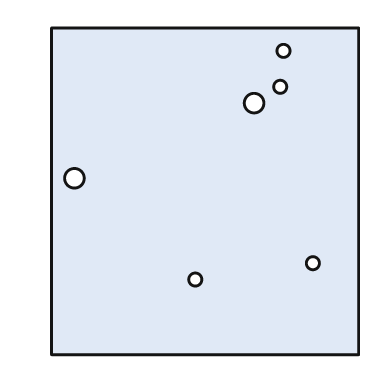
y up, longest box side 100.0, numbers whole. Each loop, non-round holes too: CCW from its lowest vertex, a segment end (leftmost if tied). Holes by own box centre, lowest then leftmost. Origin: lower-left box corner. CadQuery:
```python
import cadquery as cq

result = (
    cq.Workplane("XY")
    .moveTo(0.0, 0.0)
    .lineTo(94.0, 0.0)
    .lineTo(94.0, 100.0)
    .lineTo(0.0, 100.0)
    .close()
    .moveTo(44.0, 23.0)
    .circle(2.0)
    .moveTo(80.0, 28.0)
    .circle(2.0)
    .moveTo(7.0, 54.0)
    .circle(3.0)
    .moveTo(62.0, 77.0)
    .circle(3.0)
    .moveTo(70.0, 82.0)
    .circle(2.0)
    .moveTo(71.0, 93.0)
    .circle(2.0)
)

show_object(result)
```